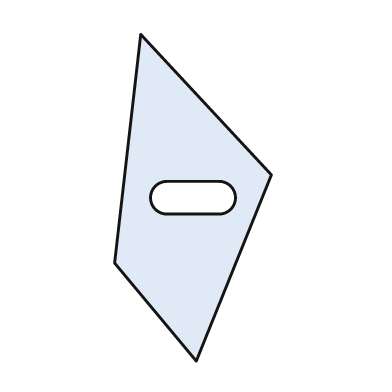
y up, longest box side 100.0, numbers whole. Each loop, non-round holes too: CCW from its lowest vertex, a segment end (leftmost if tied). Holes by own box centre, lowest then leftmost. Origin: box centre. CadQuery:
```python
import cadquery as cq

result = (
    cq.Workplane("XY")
    .moveTo(1.0, -50.0)
    .lineTo(24.0, 7.0)
    .lineTo(-16.0, 50.0)
    .lineTo(-24.0, -20.0)
    .close()
    .moveTo(-8.0, -5.0)
    .lineTo(8.0, -5.0)
    .threePointArc((13.0, 0.0), (8.0, 5.0))
    .lineTo(-8.0, 5.0)
    .threePointArc((-13.0, 0.0), (-8.0, -5.0))
    .close()
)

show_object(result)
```